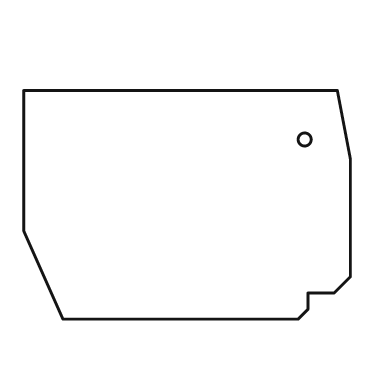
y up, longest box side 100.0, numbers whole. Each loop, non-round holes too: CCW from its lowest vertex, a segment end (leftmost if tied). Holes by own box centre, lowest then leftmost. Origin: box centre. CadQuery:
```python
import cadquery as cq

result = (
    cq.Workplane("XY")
    .moveTo(-38.0, -35.0)
    .lineTo(34.0, -35.0)
    .lineTo(37.0, -32.0)
    .lineTo(37.0, -27.0)
    .lineTo(45.0, -27.0)
    .lineTo(50.0, -22.0)
    .lineTo(50.0, 14.0)
    .lineTo(46.0, 35.0)
    .lineTo(-50.0, 35.0)
    .lineTo(-50.0, -8.0)
    .close()
    .moveTo(36.0, 20.0)
    .circle(2.0)
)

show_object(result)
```